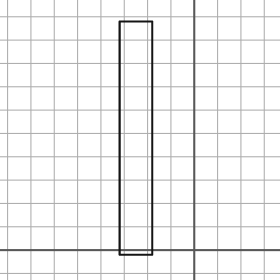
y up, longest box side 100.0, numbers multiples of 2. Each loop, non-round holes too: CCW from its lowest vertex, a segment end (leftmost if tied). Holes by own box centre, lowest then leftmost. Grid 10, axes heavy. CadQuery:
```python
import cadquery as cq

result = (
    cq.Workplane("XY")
    .moveTo(-32.0, -2.0)
    .lineTo(-18.0, -2.0)
    .lineTo(-18.0, 98.0)
    .lineTo(-32.0, 98.0)
    .close()
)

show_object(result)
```